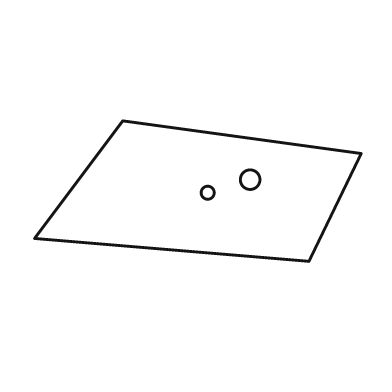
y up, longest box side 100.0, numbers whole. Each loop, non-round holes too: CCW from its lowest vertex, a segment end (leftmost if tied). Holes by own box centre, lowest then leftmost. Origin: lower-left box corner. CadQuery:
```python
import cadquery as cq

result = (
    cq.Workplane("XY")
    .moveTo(84.0, 0.0)
    .lineTo(100.0, 33.0)
    .lineTo(27.0, 43.0)
    .lineTo(0.0, 7.0)
    .close()
    .moveTo(53.0, 21.0)
    .circle(2.0)
    .moveTo(66.0, 25.0)
    .circle(3.0)
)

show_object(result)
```